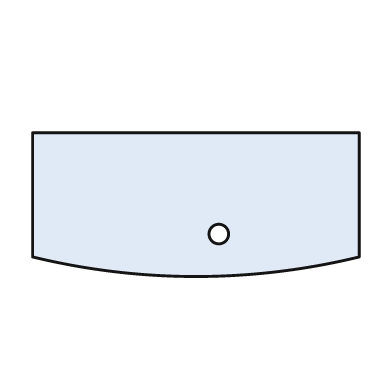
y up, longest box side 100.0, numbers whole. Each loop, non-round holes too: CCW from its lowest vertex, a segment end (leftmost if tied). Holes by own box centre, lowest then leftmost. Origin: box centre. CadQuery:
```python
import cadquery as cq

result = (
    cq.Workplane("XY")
    .moveTo(-50.0, -16.0)
    .threePointArc((0.0, -22.0), (50.0, -16.0))
    .lineTo(50.0, 22.0)
    .lineTo(-50.0, 22.0)
    .close()
    .moveTo(7.0, -9.0)
    .circle(3.0)
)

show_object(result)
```